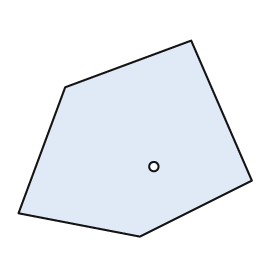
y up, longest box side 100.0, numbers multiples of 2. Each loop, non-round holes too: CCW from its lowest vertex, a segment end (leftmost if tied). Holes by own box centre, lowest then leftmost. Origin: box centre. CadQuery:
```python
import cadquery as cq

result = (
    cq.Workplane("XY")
    .moveTo(2.0, -42.0)
    .lineTo(50.0, -18.0)
    .lineTo(24.0, 42.0)
    .lineTo(-30.0, 22.0)
    .lineTo(-50.0, -32.0)
    .close()
    .moveTo(8.0, -12.0)
    .circle(2.0)
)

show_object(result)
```